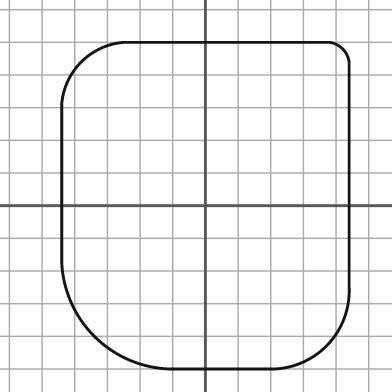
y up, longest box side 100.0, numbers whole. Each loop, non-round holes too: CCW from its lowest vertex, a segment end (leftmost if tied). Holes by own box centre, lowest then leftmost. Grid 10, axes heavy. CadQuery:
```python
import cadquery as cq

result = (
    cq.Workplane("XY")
    .moveTo(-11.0, -50.0)
    .lineTo(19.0, -50.0)
    .threePointArc((37.0, -43.0), (44.0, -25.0))
    .lineTo(44.0, 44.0)
    .threePointArc((42.0, 48.0), (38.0, 50.0))
    .lineTo(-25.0, 50.0)
    .threePointArc((-38.0, 44.0), (-44.0, 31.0))
    .lineTo(-44.0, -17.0)
    .threePointArc((-34.0, -40.0), (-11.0, -50.0))
    .close()
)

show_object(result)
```